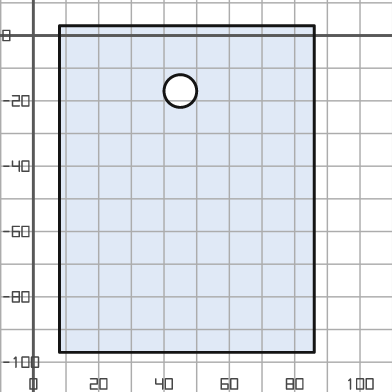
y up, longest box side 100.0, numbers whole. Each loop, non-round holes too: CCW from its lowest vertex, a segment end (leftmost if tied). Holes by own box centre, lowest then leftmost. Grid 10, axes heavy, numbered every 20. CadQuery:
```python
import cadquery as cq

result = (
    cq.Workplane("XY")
    .moveTo(8.0, -97.0)
    .lineTo(86.0, -97.0)
    .lineTo(86.0, 3.0)
    .lineTo(8.0, 3.0)
    .close()
    .moveTo(45.0, -17.0)
    .circle(5.0)
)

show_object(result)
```